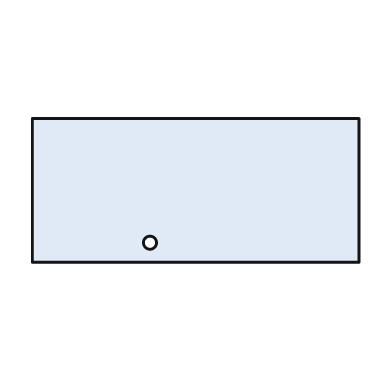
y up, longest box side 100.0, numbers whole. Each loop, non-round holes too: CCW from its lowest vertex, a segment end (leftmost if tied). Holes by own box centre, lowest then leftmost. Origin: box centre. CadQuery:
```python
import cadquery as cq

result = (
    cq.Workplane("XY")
    .moveTo(-50.0, -22.0)
    .lineTo(50.0, -22.0)
    .lineTo(50.0, 22.0)
    .lineTo(-50.0, 22.0)
    .close()
    .moveTo(-14.0, -16.0)
    .circle(2.0)
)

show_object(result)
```